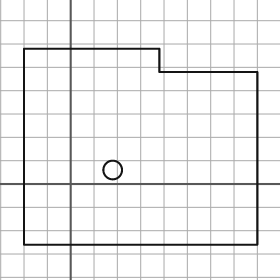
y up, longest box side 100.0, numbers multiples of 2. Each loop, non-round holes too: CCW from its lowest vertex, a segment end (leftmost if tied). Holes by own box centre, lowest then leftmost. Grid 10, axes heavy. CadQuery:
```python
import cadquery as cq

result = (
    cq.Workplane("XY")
    .moveTo(-20.0, -26.0)
    .lineTo(80.0, -26.0)
    .lineTo(80.0, 48.0)
    .lineTo(38.0, 48.0)
    .lineTo(38.0, 58.0)
    .lineTo(-20.0, 58.0)
    .close()
    .moveTo(18.0, 6.0)
    .circle(4.0)
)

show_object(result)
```